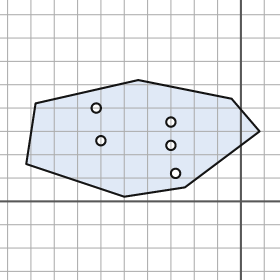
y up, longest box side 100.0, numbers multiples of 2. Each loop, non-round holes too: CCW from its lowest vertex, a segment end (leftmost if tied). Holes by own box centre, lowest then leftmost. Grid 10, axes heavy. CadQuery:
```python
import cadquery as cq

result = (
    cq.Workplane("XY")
    .moveTo(-50.0, 2.0)
    .lineTo(-24.0, 6.0)
    .lineTo(8.0, 30.0)
    .lineTo(-4.0, 44.0)
    .lineTo(-44.0, 52.0)
    .lineTo(-88.0, 42.0)
    .lineTo(-92.0, 16.0)
    .close()
    .moveTo(-28.0, 12.0)
    .circle(2.0)
    .moveTo(-30.0, 24.0)
    .circle(2.0)
    .moveTo(-60.0, 26.0)
    .circle(2.0)
    .moveTo(-30.0, 34.0)
    .circle(2.0)
    .moveTo(-62.0, 40.0)
    .circle(2.0)
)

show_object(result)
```